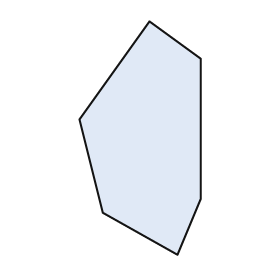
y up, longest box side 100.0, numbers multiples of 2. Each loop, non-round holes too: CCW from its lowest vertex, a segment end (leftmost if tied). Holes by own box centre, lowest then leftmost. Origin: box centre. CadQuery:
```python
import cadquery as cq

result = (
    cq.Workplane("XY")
    .moveTo(16.0, -50.0)
    .lineTo(26.0, -26.0)
    .lineTo(26.0, 34.0)
    .lineTo(4.0, 50.0)
    .lineTo(-26.0, 8.0)
    .lineTo(-16.0, -32.0)
    .close()
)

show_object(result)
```